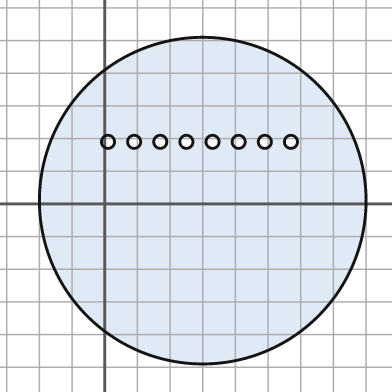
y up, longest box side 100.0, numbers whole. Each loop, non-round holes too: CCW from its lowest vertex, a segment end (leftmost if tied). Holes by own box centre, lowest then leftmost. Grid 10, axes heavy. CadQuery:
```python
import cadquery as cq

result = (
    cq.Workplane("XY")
    .moveTo(30.0, 1.0)
    .circle(50.0)
    .moveTo(1.0, 19.0)
    .circle(2.0)
    .moveTo(9.0, 19.0)
    .circle(2.0)
    .moveTo(17.0, 19.0)
    .circle(2.0)
    .moveTo(25.0, 19.0)
    .circle(2.0)
    .moveTo(33.0, 19.0)
    .circle(2.0)
    .moveTo(41.0, 19.0)
    .circle(2.0)
    .moveTo(49.0, 19.0)
    .circle(2.0)
    .moveTo(57.0, 19.0)
    .circle(2.0)
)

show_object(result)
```